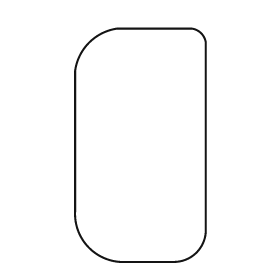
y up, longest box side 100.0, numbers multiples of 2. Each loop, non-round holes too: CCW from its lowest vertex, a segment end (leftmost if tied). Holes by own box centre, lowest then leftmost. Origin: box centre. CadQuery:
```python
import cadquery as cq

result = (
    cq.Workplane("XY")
    .moveTo(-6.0, -50.0)
    .lineTo(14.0, -50.0)
    .threePointArc((24.0, -46.0), (28.0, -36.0))
    .lineTo(28.0, 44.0)
    .threePointArc((26.0, 48.0), (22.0, 50.0))
    .lineTo(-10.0, 50.0)
    .threePointArc((-22.0, 44.0), (-28.0, 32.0))
    .lineTo(-28.0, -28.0)
    .threePointArc((-22.0, -44.0), (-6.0, -50.0))
    .close()
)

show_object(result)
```